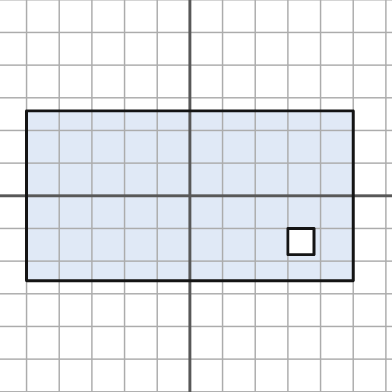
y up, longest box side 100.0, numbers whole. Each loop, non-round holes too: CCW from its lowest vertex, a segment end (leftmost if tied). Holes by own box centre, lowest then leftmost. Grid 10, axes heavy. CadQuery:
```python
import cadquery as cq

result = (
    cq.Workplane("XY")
    .moveTo(-50.0, -26.0)
    .lineTo(50.0, -26.0)
    .lineTo(50.0, 26.0)
    .lineTo(-50.0, 26.0)
    .close()
    .moveTo(30.0, -18.0)
    .lineTo(38.0, -18.0)
    .lineTo(38.0, -10.0)
    .lineTo(30.0, -10.0)
    .close()
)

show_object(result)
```